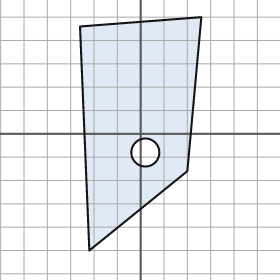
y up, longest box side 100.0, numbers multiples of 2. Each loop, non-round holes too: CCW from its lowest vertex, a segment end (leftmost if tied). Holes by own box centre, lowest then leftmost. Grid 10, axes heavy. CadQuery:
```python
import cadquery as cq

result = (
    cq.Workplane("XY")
    .moveTo(-22.0, -50.0)
    .lineTo(20.0, -16.0)
    .lineTo(26.0, 50.0)
    .lineTo(-26.0, 46.0)
    .close()
    .moveTo(2.0, -8.0)
    .circle(6.0)
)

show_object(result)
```